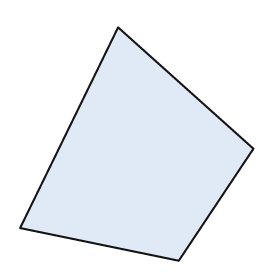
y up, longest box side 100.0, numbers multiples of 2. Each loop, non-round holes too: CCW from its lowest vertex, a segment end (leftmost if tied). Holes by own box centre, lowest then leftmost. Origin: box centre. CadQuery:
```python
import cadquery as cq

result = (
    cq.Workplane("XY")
    .moveTo(18.0, -50.0)
    .lineTo(50.0, -2.0)
    .lineTo(-8.0, 50.0)
    .lineTo(-50.0, -36.0)
    .close()
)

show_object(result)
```